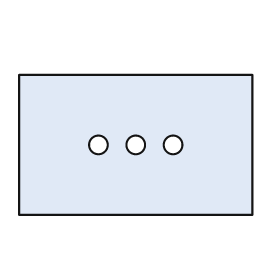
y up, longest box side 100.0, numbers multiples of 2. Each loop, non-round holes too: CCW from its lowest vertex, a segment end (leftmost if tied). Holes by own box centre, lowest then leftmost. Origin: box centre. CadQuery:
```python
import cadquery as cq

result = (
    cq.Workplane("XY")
    .moveTo(-50.0, -30.0)
    .lineTo(50.0, -30.0)
    .lineTo(50.0, 30.0)
    .lineTo(-50.0, 30.0)
    .close()
    .moveTo(-16.0, 0.0)
    .circle(4.0)
    .moveTo(0.0, 0.0)
    .circle(4.0)
    .moveTo(16.0, 0.0)
    .circle(4.0)
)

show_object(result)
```